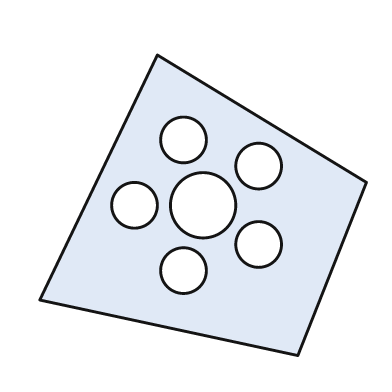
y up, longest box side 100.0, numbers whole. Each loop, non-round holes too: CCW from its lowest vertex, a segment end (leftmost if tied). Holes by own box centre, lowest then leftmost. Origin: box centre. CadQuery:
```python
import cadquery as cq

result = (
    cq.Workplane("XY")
    .moveTo(29.0, -46.0)
    .lineTo(50.0, 7.0)
    .lineTo(-14.0, 46.0)
    .lineTo(-50.0, -29.0)
    .close()
    .moveTo(-6.0, -20.0)
    .circle(7.0)
    .moveTo(17.0, -12.0)
    .circle(7.0)
    .moveTo(-21.0, 0.0)
    .circle(7.0)
    .moveTo(0.0, 0.0)
    .circle(10.0)
    .moveTo(17.0, 12.0)
    .circle(7.0)
    .moveTo(-6.0, 20.0)
    .circle(7.0)
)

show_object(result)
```